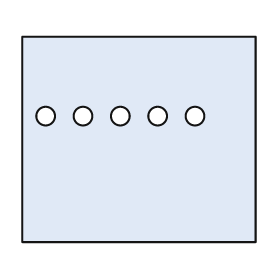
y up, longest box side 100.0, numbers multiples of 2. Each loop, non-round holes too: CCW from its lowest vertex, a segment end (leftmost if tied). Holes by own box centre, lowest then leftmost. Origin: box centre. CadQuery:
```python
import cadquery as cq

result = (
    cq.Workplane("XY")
    .moveTo(-50.0, -44.0)
    .lineTo(50.0, -44.0)
    .lineTo(50.0, 44.0)
    .lineTo(-50.0, 44.0)
    .close()
    .moveTo(-40.0, 10.0)
    .circle(4.0)
    .moveTo(-24.0, 10.0)
    .circle(4.0)
    .moveTo(-8.0, 10.0)
    .circle(4.0)
    .moveTo(8.0, 10.0)
    .circle(4.0)
    .moveTo(24.0, 10.0)
    .circle(4.0)
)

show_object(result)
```